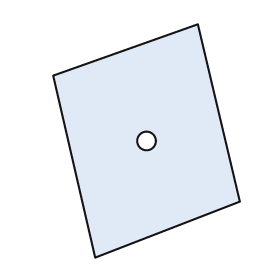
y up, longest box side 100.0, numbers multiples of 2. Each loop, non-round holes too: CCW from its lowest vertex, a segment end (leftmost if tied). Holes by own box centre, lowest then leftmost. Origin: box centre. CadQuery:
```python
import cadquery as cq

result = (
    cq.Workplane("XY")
    .moveTo(-22.0, -50.0)
    .lineTo(40.0, -26.0)
    .lineTo(22.0, 50.0)
    .lineTo(-40.0, 28.0)
    .close()
    .moveTo(0.0, 0.0)
    .circle(4.0)
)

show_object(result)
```